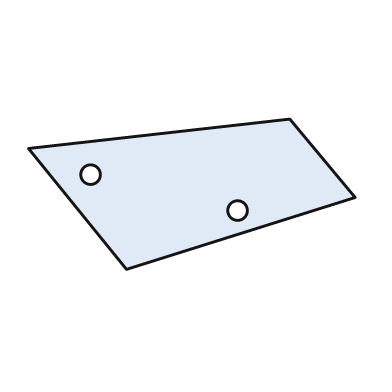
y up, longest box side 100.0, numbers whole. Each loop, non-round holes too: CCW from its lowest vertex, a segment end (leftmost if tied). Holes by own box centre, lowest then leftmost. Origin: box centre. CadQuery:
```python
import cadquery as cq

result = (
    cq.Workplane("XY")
    .moveTo(-20.0, -23.0)
    .lineTo(50.0, -1.0)
    .lineTo(30.0, 23.0)
    .lineTo(-50.0, 14.0)
    .close()
    .moveTo(14.0, -5.0)
    .circle(3.0)
    .moveTo(-31.0, 6.0)
    .circle(3.0)
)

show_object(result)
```